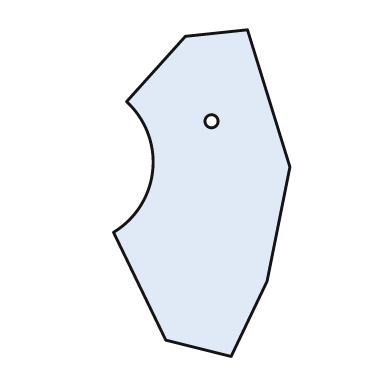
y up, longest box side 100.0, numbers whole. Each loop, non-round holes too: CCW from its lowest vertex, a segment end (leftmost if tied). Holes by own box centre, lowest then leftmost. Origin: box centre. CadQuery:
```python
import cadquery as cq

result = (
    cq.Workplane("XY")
    .moveTo(9.0, -50.0)
    .lineTo(20.0, -27.0)
    .lineTo(27.0, 8.0)
    .lineTo(14.0, 50.0)
    .lineTo(-5.0, 48.0)
    .lineTo(-23.0, 28.0)
    .threePointArc((-15.0, 7.0), (-27.0, -12.0))
    .lineTo(-11.0, -45.0)
    .close()
    .moveTo(3.0, 22.0)
    .circle(2.0)
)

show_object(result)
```